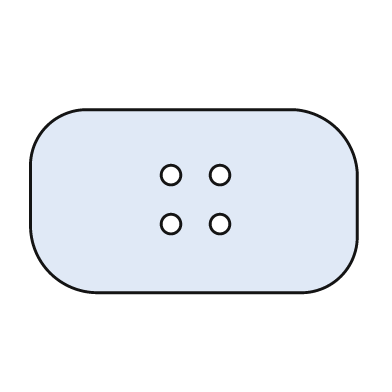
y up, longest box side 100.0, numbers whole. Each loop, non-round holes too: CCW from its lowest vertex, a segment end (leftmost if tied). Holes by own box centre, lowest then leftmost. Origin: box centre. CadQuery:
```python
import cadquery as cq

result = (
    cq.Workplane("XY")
    .moveTo(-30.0, -28.0)
    .lineTo(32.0, -28.0)
    .threePointArc((45.0, -23.0), (50.0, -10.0))
    .lineTo(50.0, 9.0)
    .threePointArc((44.0, 22.0), (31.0, 28.0))
    .lineTo(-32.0, 28.0)
    .threePointArc((-45.0, 23.0), (-50.0, 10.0))
    .lineTo(-50.0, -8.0)
    .threePointArc((-44.0, -22.0), (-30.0, -28.0))
    .close()
    .moveTo(-7.0, -7.0)
    .circle(3.0)
    .moveTo(8.0, -7.0)
    .circle(3.0)
    .moveTo(-7.0, 8.0)
    .circle(3.0)
    .moveTo(8.0, 8.0)
    .circle(3.0)
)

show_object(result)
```